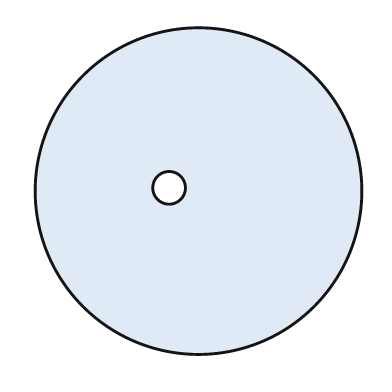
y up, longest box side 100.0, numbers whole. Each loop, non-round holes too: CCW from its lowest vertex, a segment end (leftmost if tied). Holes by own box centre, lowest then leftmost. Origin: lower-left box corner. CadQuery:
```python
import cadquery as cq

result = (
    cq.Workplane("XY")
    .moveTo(50.0, 50.0)
    .circle(50.0)
    .moveTo(41.0, 51.0)
    .circle(5.0)
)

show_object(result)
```